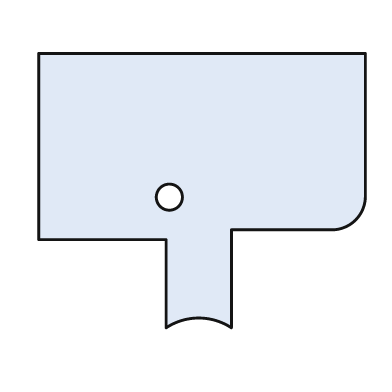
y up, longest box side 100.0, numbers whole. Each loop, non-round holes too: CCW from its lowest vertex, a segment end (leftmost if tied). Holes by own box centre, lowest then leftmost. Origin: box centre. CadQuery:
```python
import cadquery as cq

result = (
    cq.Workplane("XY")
    .moveTo(-11.0, -42.0)
    .threePointArc((-1.0, -39.0), (9.0, -42.0))
    .lineTo(9.0, -12.0)
    .lineTo(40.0, -12.0)
    .threePointArc((47.0, -9.0), (50.0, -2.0))
    .lineTo(50.0, 42.0)
    .lineTo(-50.0, 42.0)
    .lineTo(-50.0, -15.0)
    .lineTo(-11.0, -15.0)
    .close()
    .moveTo(-10.0, -2.0)
    .circle(4.0)
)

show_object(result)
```